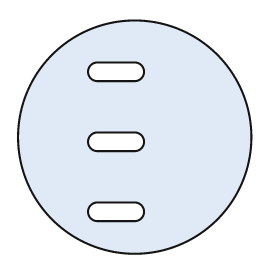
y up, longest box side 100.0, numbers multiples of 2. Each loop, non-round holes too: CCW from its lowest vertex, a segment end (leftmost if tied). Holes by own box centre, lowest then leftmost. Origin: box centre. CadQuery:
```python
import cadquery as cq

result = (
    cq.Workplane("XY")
    .moveTo(0.0, 0.0)
    .circle(50.0)
    .moveTo(-16.0, -36.0)
    .lineTo(0.0, -36.0)
    .threePointArc((4.0, -32.0), (0.0, -28.0))
    .lineTo(-16.0, -28.0)
    .threePointArc((-20.0, -32.0), (-16.0, -36.0))
    .close()
    .moveTo(-16.0, -6.0)
    .lineTo(0.0, -6.0)
    .threePointArc((4.0, -2.0), (0.0, 2.0))
    .lineTo(-16.0, 2.0)
    .threePointArc((-20.0, -2.0), (-16.0, -6.0))
    .close()
    .moveTo(-16.0, 24.0)
    .lineTo(0.0, 24.0)
    .threePointArc((4.0, 28.0), (0.0, 32.0))
    .lineTo(-16.0, 32.0)
    .threePointArc((-20.0, 28.0), (-16.0, 24.0))
    .close()
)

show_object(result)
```